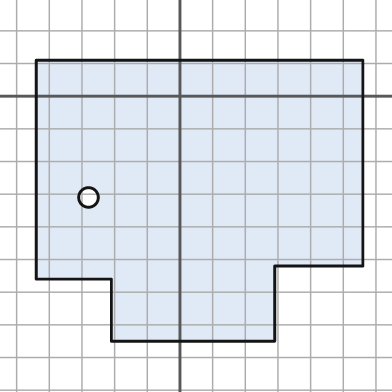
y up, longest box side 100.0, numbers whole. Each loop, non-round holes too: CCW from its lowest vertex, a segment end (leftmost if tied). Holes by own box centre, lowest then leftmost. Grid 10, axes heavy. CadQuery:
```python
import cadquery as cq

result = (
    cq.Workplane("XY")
    .moveTo(-21.0, -75.0)
    .lineTo(29.0, -75.0)
    .lineTo(29.0, -52.0)
    .lineTo(56.0, -52.0)
    .lineTo(56.0, 11.0)
    .lineTo(-44.0, 11.0)
    .lineTo(-44.0, -56.0)
    .lineTo(-21.0, -56.0)
    .close()
    .moveTo(-28.0, -31.0)
    .circle(3.0)
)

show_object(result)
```